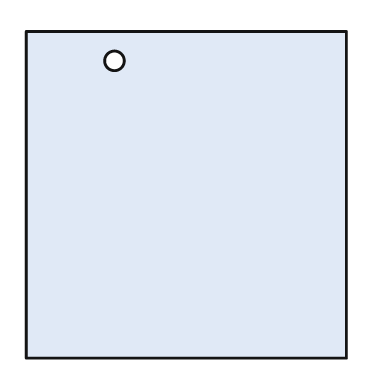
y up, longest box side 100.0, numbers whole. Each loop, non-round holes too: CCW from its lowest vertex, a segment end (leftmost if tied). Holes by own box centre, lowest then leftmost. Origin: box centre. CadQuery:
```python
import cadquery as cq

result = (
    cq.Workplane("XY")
    .moveTo(-49.0, -50.0)
    .lineTo(49.0, -50.0)
    .lineTo(49.0, 50.0)
    .lineTo(-49.0, 50.0)
    .close()
    .moveTo(-22.0, 41.0)
    .circle(3.0)
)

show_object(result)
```